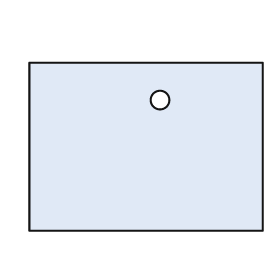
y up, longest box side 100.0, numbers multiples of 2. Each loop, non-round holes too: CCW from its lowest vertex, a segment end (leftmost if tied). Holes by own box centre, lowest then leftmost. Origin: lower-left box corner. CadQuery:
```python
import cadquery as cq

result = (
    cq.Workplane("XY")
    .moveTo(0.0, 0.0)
    .lineTo(100.0, 0.0)
    .lineTo(100.0, 72.0)
    .lineTo(0.0, 72.0)
    .close()
    .moveTo(56.0, 56.0)
    .circle(4.0)
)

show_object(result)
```